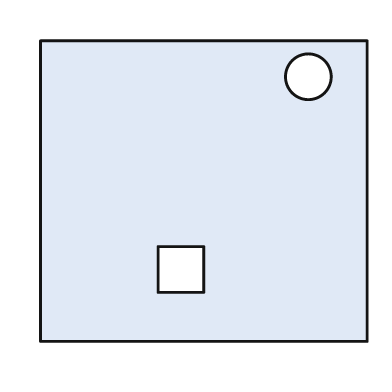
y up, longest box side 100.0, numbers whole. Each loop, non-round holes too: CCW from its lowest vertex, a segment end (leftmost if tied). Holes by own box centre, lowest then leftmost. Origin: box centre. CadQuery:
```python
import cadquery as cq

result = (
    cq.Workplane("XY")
    .moveTo(-50.0, -46.0)
    .lineTo(50.0, -46.0)
    .lineTo(50.0, 46.0)
    .lineTo(-50.0, 46.0)
    .close()
    .moveTo(-14.0, -31.0)
    .lineTo(0.0, -31.0)
    .lineTo(0.0, -17.0)
    .lineTo(-14.0, -17.0)
    .close()
    .moveTo(32.0, 35.0)
    .circle(7.0)
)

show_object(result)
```